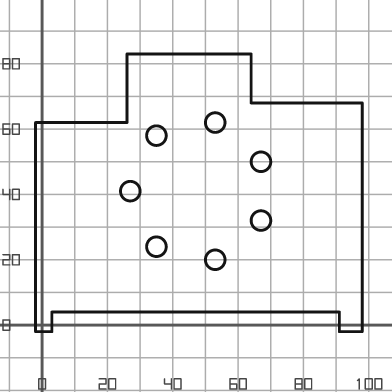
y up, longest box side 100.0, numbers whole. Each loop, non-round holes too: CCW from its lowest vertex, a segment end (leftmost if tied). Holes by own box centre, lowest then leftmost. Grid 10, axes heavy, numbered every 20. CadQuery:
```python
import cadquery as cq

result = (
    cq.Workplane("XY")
    .moveTo(-2.0, -2.0)
    .lineTo(3.0, -2.0)
    .lineTo(3.0, 4.0)
    .lineTo(91.0, 4.0)
    .lineTo(91.0, -2.0)
    .lineTo(98.0, -2.0)
    .lineTo(98.0, 68.0)
    .lineTo(64.0, 68.0)
    .lineTo(64.0, 83.0)
    .lineTo(26.0, 83.0)
    .lineTo(26.0, 62.0)
    .lineTo(-2.0, 62.0)
    .close()
    .moveTo(53.0, 20.0)
    .circle(3.0)
    .moveTo(35.0, 24.0)
    .circle(3.0)
    .moveTo(67.0, 32.0)
    .circle(3.0)
    .moveTo(27.0, 41.0)
    .circle(3.0)
    .moveTo(67.0, 50.0)
    .circle(3.0)
    .moveTo(35.0, 58.0)
    .circle(3.0)
    .moveTo(53.0, 62.0)
    .circle(3.0)
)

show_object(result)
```